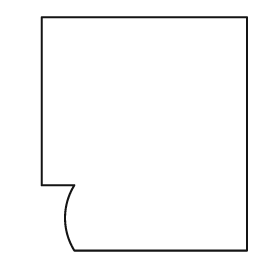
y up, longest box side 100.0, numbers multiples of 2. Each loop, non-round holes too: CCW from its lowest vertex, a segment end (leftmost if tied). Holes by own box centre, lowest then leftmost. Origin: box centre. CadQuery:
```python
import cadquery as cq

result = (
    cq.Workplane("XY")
    .moveTo(-30.0, -50.0)
    .lineTo(44.0, -50.0)
    .lineTo(44.0, 50.0)
    .lineTo(-44.0, 50.0)
    .lineTo(-44.0, -22.0)
    .lineTo(-30.0, -22.0)
    .threePointArc((-34.0, -36.0), (-30.0, -50.0))
    .close()
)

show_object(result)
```